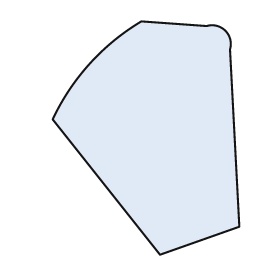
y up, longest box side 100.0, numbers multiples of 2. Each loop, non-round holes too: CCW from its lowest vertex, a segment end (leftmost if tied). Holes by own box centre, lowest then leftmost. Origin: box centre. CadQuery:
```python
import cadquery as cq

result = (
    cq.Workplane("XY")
    .moveTo(6.0, -50.0)
    .lineTo(40.0, -38.0)
    .lineTo(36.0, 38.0)
    .threePointArc((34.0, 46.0), (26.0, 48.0))
    .lineTo(-2.0, 50.0)
    .threePointArc((-24.0, 32.0), (-40.0, 8.0))
    .close()
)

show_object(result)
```